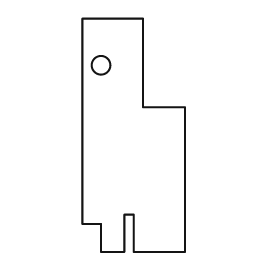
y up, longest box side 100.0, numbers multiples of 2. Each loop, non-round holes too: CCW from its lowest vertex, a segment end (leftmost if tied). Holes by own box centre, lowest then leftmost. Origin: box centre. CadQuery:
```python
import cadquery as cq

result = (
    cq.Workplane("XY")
    .moveTo(-14.0, -50.0)
    .lineTo(-4.0, -50.0)
    .lineTo(-4.0, -34.0)
    .lineTo(0.0, -34.0)
    .lineTo(0.0, -50.0)
    .lineTo(22.0, -50.0)
    .lineTo(22.0, 12.0)
    .lineTo(4.0, 12.0)
    .lineTo(4.0, 50.0)
    .lineTo(-22.0, 50.0)
    .lineTo(-22.0, -38.0)
    .lineTo(-14.0, -38.0)
    .close()
    .moveTo(-14.0, 30.0)
    .circle(4.0)
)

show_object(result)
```